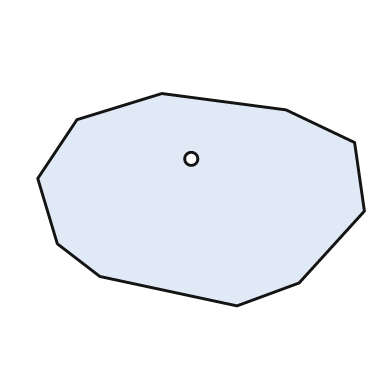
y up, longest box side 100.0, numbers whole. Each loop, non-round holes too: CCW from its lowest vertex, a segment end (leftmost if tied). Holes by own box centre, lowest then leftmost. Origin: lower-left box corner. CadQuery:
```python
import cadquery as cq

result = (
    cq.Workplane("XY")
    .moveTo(61.0, 0.0)
    .lineTo(80.0, 7.0)
    .lineTo(100.0, 29.0)
    .lineTo(97.0, 50.0)
    .lineTo(76.0, 60.0)
    .lineTo(38.0, 65.0)
    .lineTo(12.0, 57.0)
    .lineTo(0.0, 39.0)
    .lineTo(6.0, 19.0)
    .lineTo(19.0, 9.0)
    .close()
    .moveTo(47.0, 45.0)
    .circle(2.0)
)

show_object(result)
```